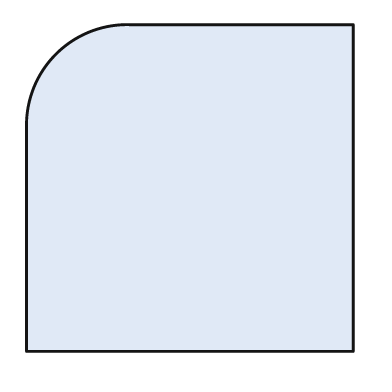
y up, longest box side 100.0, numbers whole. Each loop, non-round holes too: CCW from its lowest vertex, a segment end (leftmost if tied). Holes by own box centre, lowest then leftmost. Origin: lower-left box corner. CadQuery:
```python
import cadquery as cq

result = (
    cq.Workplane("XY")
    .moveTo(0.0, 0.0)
    .lineTo(100.0, 0.0)
    .lineTo(100.0, 100.0)
    .lineTo(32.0, 100.0)
    .threePointArc((9.0, 91.0), (0.0, 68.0))
    .close()
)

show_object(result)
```